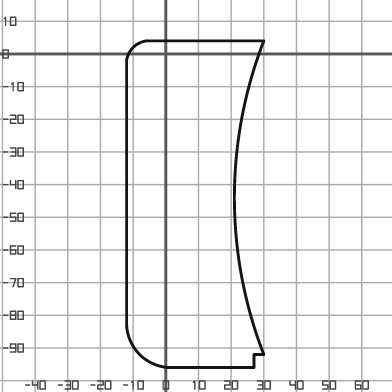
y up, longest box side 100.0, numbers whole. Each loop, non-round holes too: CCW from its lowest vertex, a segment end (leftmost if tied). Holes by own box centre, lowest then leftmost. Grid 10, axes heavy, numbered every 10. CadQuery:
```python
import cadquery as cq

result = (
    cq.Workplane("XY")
    .moveTo(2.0, -96.0)
    .lineTo(27.0, -96.0)
    .lineTo(27.0, -92.0)
    .lineTo(30.0, -92.0)
    .threePointArc((21.0, -44.0), (30.0, 4.0))
    .lineTo(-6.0, 4.0)
    .threePointArc((-10.0, 2.0), (-12.0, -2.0))
    .lineTo(-12.0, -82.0)
    .threePointArc((-8.0, -92.0), (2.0, -96.0))
    .close()
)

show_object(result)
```